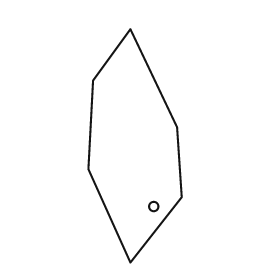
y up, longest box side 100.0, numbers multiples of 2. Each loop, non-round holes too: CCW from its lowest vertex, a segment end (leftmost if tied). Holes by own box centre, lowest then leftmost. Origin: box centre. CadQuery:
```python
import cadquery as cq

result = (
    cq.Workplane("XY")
    .moveTo(-2.0, -50.0)
    .lineTo(20.0, -22.0)
    .lineTo(18.0, 8.0)
    .lineTo(-2.0, 50.0)
    .lineTo(-18.0, 28.0)
    .lineTo(-20.0, -10.0)
    .close()
    .moveTo(8.0, -26.0)
    .circle(2.0)
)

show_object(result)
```